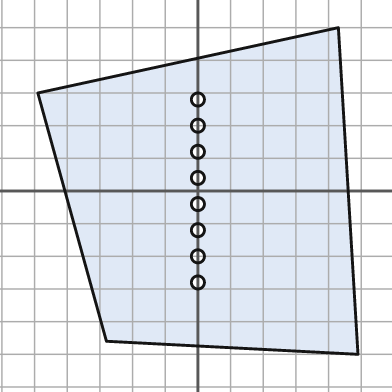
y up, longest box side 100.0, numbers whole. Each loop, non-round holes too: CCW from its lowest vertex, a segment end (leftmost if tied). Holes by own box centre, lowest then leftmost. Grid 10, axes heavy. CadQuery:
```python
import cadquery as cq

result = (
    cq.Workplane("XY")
    .moveTo(49.0, -50.0)
    .lineTo(43.0, 50.0)
    .lineTo(-49.0, 30.0)
    .lineTo(-28.0, -46.0)
    .close()
    .moveTo(0.0, -28.0)
    .circle(2.0)
    .moveTo(0.0, -20.0)
    .circle(2.0)
    .moveTo(0.0, -12.0)
    .circle(2.0)
    .moveTo(0.0, -4.0)
    .circle(2.0)
    .moveTo(0.0, 4.0)
    .circle(2.0)
    .moveTo(0.0, 12.0)
    .circle(2.0)
    .moveTo(0.0, 20.0)
    .circle(2.0)
    .moveTo(0.0, 28.0)
    .circle(2.0)
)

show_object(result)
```